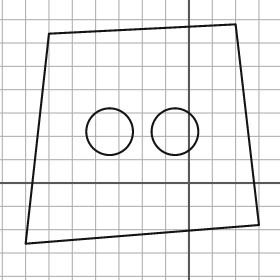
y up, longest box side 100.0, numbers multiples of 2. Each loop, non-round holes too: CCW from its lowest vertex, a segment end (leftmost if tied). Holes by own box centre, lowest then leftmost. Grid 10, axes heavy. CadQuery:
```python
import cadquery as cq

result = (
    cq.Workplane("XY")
    .moveTo(-70.0, -26.0)
    .lineTo(30.0, -18.0)
    .lineTo(20.0, 68.0)
    .lineTo(-60.0, 64.0)
    .close()
    .moveTo(-34.0, 22.0)
    .circle(10.0)
    .moveTo(-6.0, 22.0)
    .circle(10.0)
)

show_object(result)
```